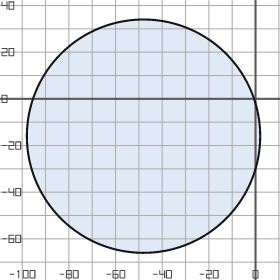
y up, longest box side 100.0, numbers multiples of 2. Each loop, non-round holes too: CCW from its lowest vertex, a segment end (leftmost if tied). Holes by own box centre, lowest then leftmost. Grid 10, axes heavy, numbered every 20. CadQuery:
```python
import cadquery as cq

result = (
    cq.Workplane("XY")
    .moveTo(-48.0, -16.0)
    .circle(50.0)
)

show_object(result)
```